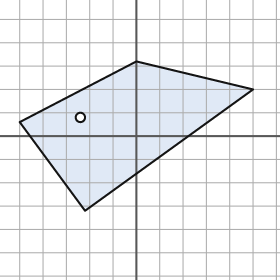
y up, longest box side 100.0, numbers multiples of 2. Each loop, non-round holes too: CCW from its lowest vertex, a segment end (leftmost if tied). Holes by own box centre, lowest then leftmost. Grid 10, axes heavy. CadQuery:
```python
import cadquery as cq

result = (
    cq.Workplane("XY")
    .moveTo(-22.0, -32.0)
    .lineTo(50.0, 20.0)
    .lineTo(0.0, 32.0)
    .lineTo(-50.0, 6.0)
    .close()
    .moveTo(-24.0, 8.0)
    .circle(2.0)
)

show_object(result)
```